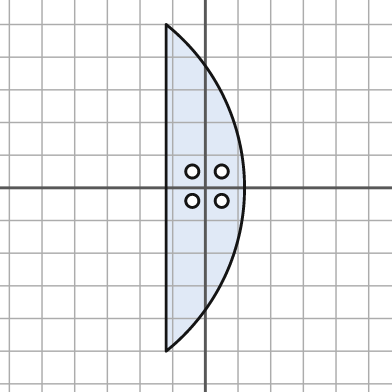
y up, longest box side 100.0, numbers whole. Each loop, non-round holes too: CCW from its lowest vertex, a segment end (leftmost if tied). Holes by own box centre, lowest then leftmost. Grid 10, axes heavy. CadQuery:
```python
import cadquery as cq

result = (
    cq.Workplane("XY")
    .moveTo(-12.0, -50.0)
    .threePointArc((12.0, 0.0), (-12.0, 50.0))
    .close()
    .moveTo(-4.0, -4.0)
    .circle(2.0)
    .moveTo(5.0, -4.0)
    .circle(2.0)
    .moveTo(-4.0, 5.0)
    .circle(2.0)
    .moveTo(5.0, 5.0)
    .circle(2.0)
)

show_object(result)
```